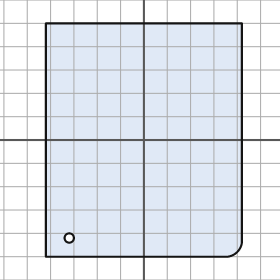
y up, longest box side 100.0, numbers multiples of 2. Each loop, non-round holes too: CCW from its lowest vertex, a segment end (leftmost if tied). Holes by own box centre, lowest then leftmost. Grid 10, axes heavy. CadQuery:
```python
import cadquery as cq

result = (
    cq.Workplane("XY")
    .moveTo(-42.0, -50.0)
    .lineTo(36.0, -50.0)
    .threePointArc((40.0, -48.0), (42.0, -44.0))
    .lineTo(42.0, 50.0)
    .lineTo(-42.0, 50.0)
    .close()
    .moveTo(-32.0, -42.0)
    .circle(2.0)
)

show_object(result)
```